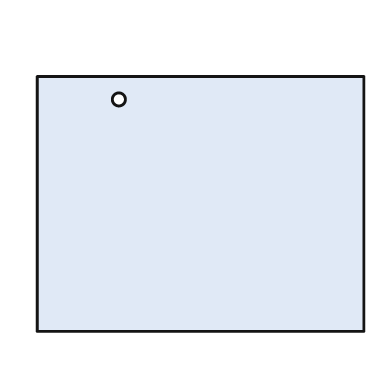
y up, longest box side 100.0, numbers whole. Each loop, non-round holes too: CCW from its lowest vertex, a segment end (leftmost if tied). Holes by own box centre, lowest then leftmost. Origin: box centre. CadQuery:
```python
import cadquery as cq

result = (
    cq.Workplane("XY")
    .moveTo(-50.0, -39.0)
    .lineTo(50.0, -39.0)
    .lineTo(50.0, 39.0)
    .lineTo(-50.0, 39.0)
    .close()
    .moveTo(-25.0, 32.0)
    .circle(2.0)
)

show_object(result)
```